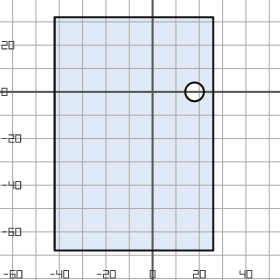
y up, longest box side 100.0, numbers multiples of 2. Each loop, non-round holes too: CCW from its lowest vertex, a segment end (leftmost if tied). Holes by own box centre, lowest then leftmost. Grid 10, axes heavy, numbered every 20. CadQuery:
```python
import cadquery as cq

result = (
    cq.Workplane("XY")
    .moveTo(-42.0, -68.0)
    .lineTo(26.0, -68.0)
    .lineTo(26.0, 32.0)
    .lineTo(-42.0, 32.0)
    .close()
    .moveTo(18.0, 0.0)
    .circle(4.0)
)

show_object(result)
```